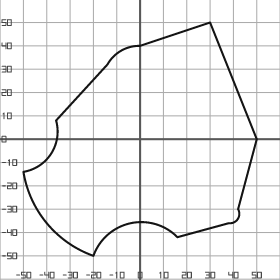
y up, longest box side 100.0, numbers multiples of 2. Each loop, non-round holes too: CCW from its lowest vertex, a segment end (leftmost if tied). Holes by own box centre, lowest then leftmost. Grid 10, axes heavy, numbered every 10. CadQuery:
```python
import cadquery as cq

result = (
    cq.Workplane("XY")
    .moveTo(-20.0, -50.0)
    .threePointArc((-4.0, -36.0), (16.0, -42.0))
    .lineTo(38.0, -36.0)
    .threePointArc((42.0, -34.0), (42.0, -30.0))
    .lineTo(50.0, 0.0)
    .lineTo(30.0, 50.0)
    .lineTo(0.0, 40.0)
    .threePointArc((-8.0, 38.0), (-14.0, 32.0))
    .lineTo(-36.0, 8.0)
    .threePointArc((-38.0, -6.0), (-50.0, -14.0))
    .threePointArc((-40.0, -36.0), (-20.0, -50.0))
    .close()
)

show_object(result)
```